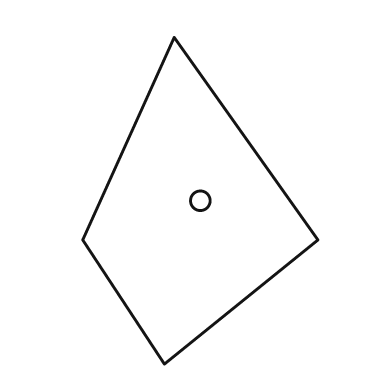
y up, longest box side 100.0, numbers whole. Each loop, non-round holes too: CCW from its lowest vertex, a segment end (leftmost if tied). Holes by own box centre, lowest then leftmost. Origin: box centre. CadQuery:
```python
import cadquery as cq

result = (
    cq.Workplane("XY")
    .moveTo(-11.0, -50.0)
    .lineTo(36.0, -12.0)
    .lineTo(-8.0, 50.0)
    .lineTo(-36.0, -12.0)
    .close()
    .moveTo(0.0, 0.0)
    .circle(3.0)
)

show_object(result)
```